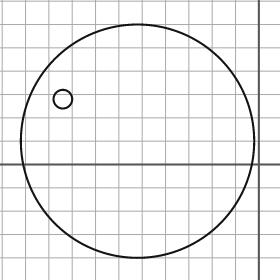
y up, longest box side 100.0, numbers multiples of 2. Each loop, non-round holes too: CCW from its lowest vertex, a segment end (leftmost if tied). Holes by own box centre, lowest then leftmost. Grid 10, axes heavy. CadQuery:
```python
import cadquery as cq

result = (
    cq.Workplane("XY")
    .moveTo(-52.0, 10.0)
    .circle(50.0)
    .moveTo(-84.0, 28.0)
    .circle(4.0)
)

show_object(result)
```